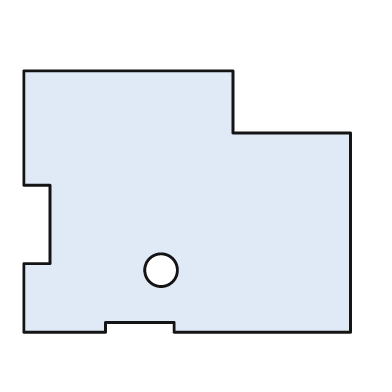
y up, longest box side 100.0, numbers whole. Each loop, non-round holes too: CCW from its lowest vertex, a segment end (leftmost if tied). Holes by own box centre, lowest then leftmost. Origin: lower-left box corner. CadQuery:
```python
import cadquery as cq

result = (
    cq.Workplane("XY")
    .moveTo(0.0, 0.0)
    .lineTo(25.0, 0.0)
    .lineTo(25.0, 3.0)
    .lineTo(46.0, 3.0)
    .lineTo(46.0, 0.0)
    .lineTo(100.0, 0.0)
    .lineTo(100.0, 61.0)
    .lineTo(64.0, 61.0)
    .lineTo(64.0, 80.0)
    .lineTo(0.0, 80.0)
    .lineTo(0.0, 45.0)
    .lineTo(8.0, 45.0)
    .lineTo(8.0, 21.0)
    .lineTo(0.0, 21.0)
    .close()
    .moveTo(42.0, 19.0)
    .circle(5.0)
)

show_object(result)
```